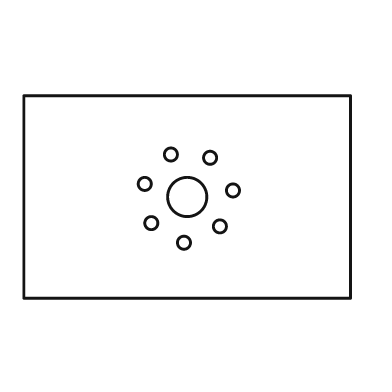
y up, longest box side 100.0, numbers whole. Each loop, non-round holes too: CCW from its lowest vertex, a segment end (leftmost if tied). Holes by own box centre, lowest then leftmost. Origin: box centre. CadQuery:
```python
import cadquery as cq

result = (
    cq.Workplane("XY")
    .moveTo(-50.0, -31.0)
    .lineTo(50.0, -31.0)
    .lineTo(50.0, 31.0)
    .lineTo(-50.0, 31.0)
    .close()
    .moveTo(-1.0, -14.0)
    .circle(2.0)
    .moveTo(10.0, -9.0)
    .circle(2.0)
    .moveTo(-11.0, -8.0)
    .circle(2.0)
    .moveTo(0.0, 0.0)
    .circle(6.0)
    .moveTo(14.0, 2.0)
    .circle(2.0)
    .moveTo(-13.0, 4.0)
    .circle(2.0)
    .moveTo(7.0, 12.0)
    .circle(2.0)
    .moveTo(-5.0, 13.0)
    .circle(2.0)
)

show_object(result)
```